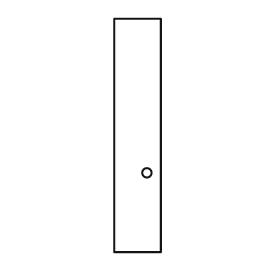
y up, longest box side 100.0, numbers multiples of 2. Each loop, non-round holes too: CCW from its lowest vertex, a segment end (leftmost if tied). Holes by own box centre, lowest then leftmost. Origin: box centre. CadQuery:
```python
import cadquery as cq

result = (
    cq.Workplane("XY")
    .moveTo(-10.0, -50.0)
    .lineTo(10.0, -50.0)
    .lineTo(10.0, 50.0)
    .lineTo(-10.0, 50.0)
    .close()
    .moveTo(4.0, -16.0)
    .circle(2.0)
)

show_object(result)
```